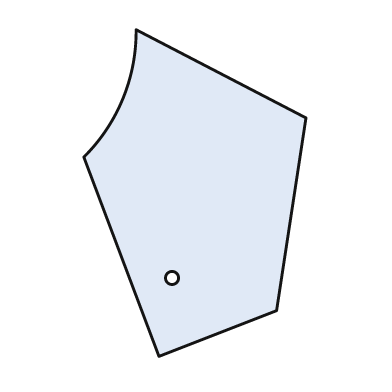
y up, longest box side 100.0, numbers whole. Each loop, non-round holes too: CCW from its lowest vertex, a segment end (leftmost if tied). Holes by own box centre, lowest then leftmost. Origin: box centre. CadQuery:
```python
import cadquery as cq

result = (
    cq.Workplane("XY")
    .moveTo(-11.0, -50.0)
    .lineTo(25.0, -36.0)
    .lineTo(34.0, 23.0)
    .lineTo(-18.0, 50.0)
    .threePointArc((-22.0, 29.0), (-34.0, 11.0))
    .close()
    .moveTo(-7.0, -26.0)
    .circle(2.0)
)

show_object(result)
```